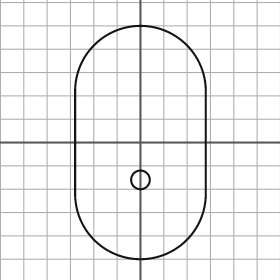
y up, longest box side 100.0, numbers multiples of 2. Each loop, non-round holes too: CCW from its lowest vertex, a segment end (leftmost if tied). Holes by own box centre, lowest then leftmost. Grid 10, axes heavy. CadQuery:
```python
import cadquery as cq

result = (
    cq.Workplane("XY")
    .moveTo(-28.0, -22.0)
    .threePointArc((0.0, -50.0), (28.0, -22.0))
    .lineTo(28.0, 22.0)
    .threePointArc((0.0, 50.0), (-28.0, 22.0))
    .close()
    .moveTo(0.0, -16.0)
    .circle(4.0)
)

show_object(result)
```